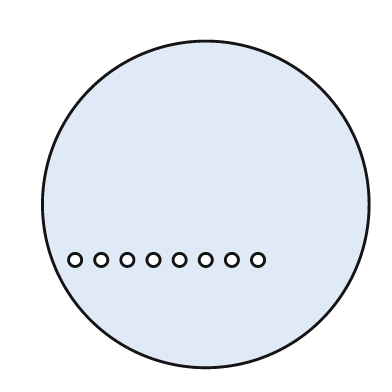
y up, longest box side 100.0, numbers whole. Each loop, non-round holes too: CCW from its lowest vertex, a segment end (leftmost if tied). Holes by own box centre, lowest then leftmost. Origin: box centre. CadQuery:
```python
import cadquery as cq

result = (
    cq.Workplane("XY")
    .moveTo(0.0, 0.0)
    .circle(50.0)
    .moveTo(-40.0, -17.0)
    .circle(2.0)
    .moveTo(-32.0, -17.0)
    .circle(2.0)
    .moveTo(-24.0, -17.0)
    .circle(2.0)
    .moveTo(-16.0, -17.0)
    .circle(2.0)
    .moveTo(-8.0, -17.0)
    .circle(2.0)
    .moveTo(0.0, -17.0)
    .circle(2.0)
    .moveTo(8.0, -17.0)
    .circle(2.0)
    .moveTo(16.0, -17.0)
    .circle(2.0)
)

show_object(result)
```